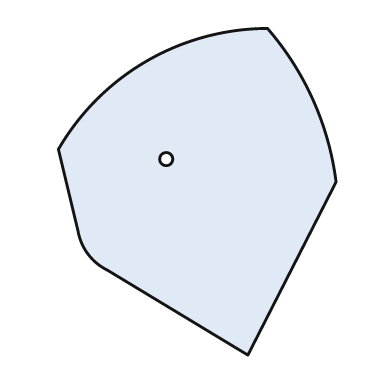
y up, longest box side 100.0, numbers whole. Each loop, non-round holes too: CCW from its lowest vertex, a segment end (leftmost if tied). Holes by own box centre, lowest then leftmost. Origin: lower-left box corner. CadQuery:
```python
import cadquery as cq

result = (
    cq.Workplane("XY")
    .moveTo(58.0, 0.0)
    .lineTo(85.0, 53.0)
    .threePointArc((78.0, 78.0), (64.0, 100.0))
    .threePointArc((27.0, 90.0), (0.0, 63.0))
    .lineTo(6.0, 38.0)
    .threePointArc((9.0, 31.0), (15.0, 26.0))
    .close()
    .moveTo(33.0, 60.0)
    .circle(2.0)
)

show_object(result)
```